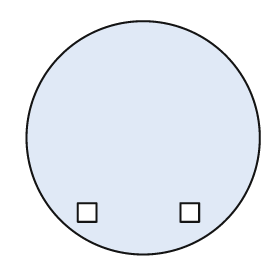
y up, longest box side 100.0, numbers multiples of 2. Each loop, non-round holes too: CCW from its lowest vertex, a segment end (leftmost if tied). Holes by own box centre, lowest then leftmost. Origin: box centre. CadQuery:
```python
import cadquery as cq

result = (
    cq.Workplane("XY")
    .moveTo(0.0, 0.0)
    .circle(50.0)
    .moveTo(-28.0, -36.0)
    .lineTo(-20.0, -36.0)
    .lineTo(-20.0, -28.0)
    .lineTo(-28.0, -28.0)
    .close()
    .moveTo(16.0, -36.0)
    .lineTo(24.0, -36.0)
    .lineTo(24.0, -28.0)
    .lineTo(16.0, -28.0)
    .close()
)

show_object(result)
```